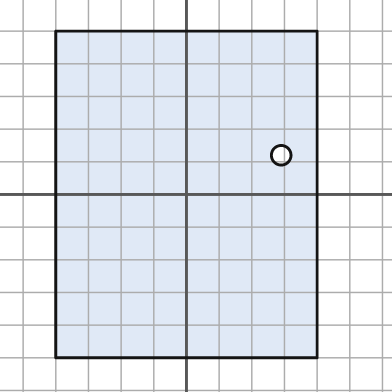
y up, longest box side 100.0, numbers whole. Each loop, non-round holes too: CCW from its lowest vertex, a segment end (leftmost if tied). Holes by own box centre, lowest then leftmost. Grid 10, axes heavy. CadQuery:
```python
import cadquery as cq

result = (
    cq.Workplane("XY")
    .moveTo(-40.0, -50.0)
    .lineTo(40.0, -50.0)
    .lineTo(40.0, 50.0)
    .lineTo(-40.0, 50.0)
    .close()
    .moveTo(29.0, 12.0)
    .circle(3.0)
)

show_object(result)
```